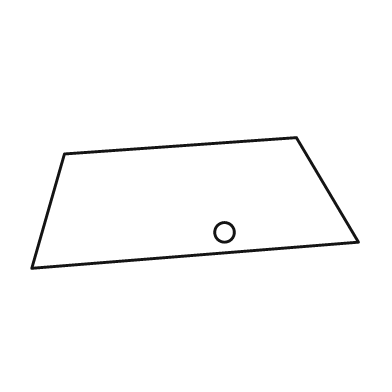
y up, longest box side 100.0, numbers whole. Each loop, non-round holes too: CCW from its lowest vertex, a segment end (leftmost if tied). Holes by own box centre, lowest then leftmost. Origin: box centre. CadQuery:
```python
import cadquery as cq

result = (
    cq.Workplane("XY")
    .moveTo(-50.0, -20.0)
    .lineTo(50.0, -12.0)
    .lineTo(31.0, 20.0)
    .lineTo(-40.0, 15.0)
    .close()
    .moveTo(9.0, -9.0)
    .circle(3.0)
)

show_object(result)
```